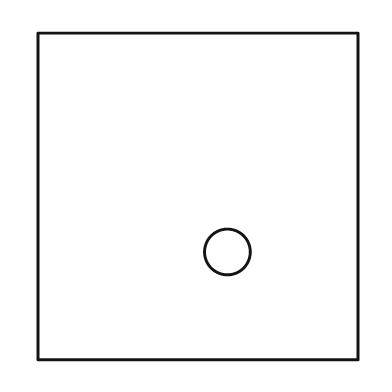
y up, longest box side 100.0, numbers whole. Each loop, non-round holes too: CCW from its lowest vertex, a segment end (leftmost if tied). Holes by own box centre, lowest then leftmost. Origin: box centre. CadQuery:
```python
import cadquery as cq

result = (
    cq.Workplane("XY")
    .moveTo(-49.0, -50.0)
    .lineTo(49.0, -50.0)
    .lineTo(49.0, 50.0)
    .lineTo(-49.0, 50.0)
    .close()
    .moveTo(9.0, -17.0)
    .circle(7.0)
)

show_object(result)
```